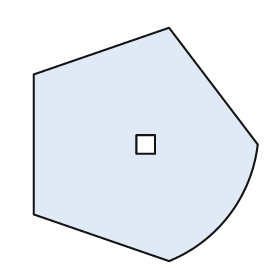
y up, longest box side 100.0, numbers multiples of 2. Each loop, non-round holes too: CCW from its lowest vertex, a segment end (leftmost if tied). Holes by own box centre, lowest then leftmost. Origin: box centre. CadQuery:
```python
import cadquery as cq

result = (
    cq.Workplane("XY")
    .moveTo(10.0, -50.0)
    .threePointArc((36.0, -30.0), (48.0, 0.0))
    .lineTo(10.0, 50.0)
    .lineTo(-48.0, 30.0)
    .lineTo(-48.0, -30.0)
    .close()
    .moveTo(-4.0, -4.0)
    .lineTo(4.0, -4.0)
    .lineTo(4.0, 4.0)
    .lineTo(-4.0, 4.0)
    .close()
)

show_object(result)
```